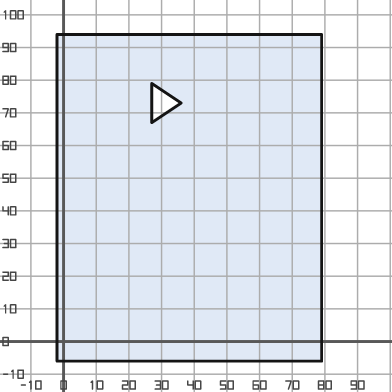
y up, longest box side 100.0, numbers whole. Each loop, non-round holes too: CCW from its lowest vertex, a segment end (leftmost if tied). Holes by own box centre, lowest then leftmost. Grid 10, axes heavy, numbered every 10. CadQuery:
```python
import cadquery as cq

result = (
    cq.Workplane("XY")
    .moveTo(-2.0, -6.0)
    .lineTo(79.0, -6.0)
    .lineTo(79.0, 94.0)
    .lineTo(-2.0, 94.0)
    .close()
    .moveTo(27.0, 67.0)
    .lineTo(36.0, 73.0)
    .lineTo(27.0, 79.0)
    .close()
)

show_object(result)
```